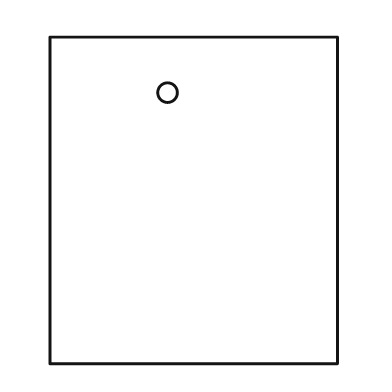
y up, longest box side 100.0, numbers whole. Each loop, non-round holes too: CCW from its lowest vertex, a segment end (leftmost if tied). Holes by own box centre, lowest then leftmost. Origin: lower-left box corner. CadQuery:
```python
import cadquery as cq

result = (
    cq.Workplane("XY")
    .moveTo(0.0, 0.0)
    .lineTo(88.0, 0.0)
    .lineTo(88.0, 100.0)
    .lineTo(0.0, 100.0)
    .close()
    .moveTo(36.0, 83.0)
    .circle(3.0)
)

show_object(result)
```